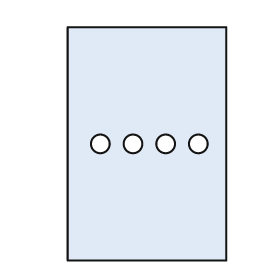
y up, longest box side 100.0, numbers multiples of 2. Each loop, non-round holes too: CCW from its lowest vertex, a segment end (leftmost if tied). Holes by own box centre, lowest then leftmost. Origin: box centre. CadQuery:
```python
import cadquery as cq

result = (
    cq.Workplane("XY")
    .moveTo(-34.0, -50.0)
    .lineTo(34.0, -50.0)
    .lineTo(34.0, 50.0)
    .lineTo(-34.0, 50.0)
    .close()
    .moveTo(-20.0, 0.0)
    .circle(4.0)
    .moveTo(-6.0, 0.0)
    .circle(4.0)
    .moveTo(8.0, 0.0)
    .circle(4.0)
    .moveTo(22.0, 0.0)
    .circle(4.0)
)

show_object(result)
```